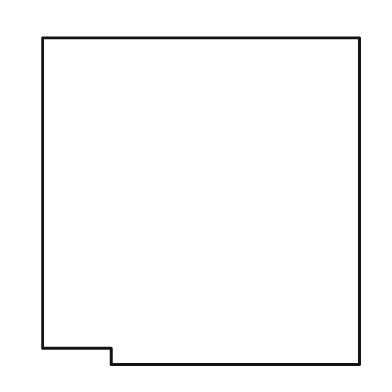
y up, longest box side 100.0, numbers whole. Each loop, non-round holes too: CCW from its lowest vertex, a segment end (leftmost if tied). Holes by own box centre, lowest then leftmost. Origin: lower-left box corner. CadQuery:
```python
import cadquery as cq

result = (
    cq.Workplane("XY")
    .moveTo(21.0, 0.0)
    .lineTo(97.0, 0.0)
    .lineTo(97.0, 100.0)
    .lineTo(0.0, 100.0)
    .lineTo(0.0, 5.0)
    .lineTo(21.0, 5.0)
    .close()
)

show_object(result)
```